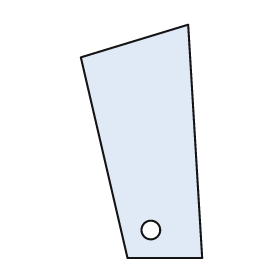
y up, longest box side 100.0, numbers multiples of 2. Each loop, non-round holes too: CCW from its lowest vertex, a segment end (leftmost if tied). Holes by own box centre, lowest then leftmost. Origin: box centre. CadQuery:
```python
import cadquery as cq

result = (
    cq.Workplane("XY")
    .moveTo(-6.0, -50.0)
    .lineTo(26.0, -50.0)
    .lineTo(20.0, 50.0)
    .lineTo(-26.0, 36.0)
    .close()
    .moveTo(4.0, -38.0)
    .circle(4.0)
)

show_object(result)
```